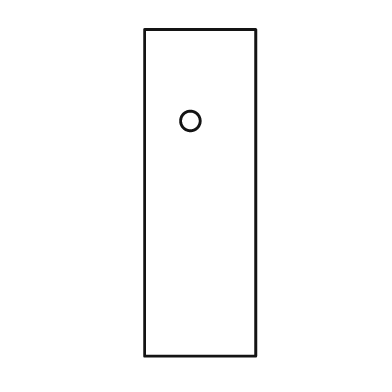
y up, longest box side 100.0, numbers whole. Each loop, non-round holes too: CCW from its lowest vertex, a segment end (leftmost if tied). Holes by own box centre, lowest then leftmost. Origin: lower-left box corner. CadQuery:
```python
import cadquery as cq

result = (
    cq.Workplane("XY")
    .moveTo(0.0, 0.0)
    .lineTo(34.0, 0.0)
    .lineTo(34.0, 100.0)
    .lineTo(0.0, 100.0)
    .close()
    .moveTo(14.0, 72.0)
    .circle(3.0)
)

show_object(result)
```